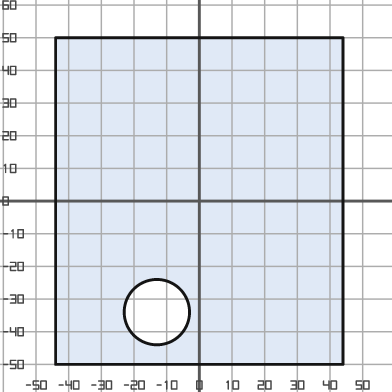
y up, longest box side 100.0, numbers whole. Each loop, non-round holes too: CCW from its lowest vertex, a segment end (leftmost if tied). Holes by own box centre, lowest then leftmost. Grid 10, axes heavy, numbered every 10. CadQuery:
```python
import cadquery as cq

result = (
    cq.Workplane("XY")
    .moveTo(-44.0, -50.0)
    .lineTo(44.0, -50.0)
    .lineTo(44.0, 50.0)
    .lineTo(-44.0, 50.0)
    .close()
    .moveTo(-13.0, -34.0)
    .circle(10.0)
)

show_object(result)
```